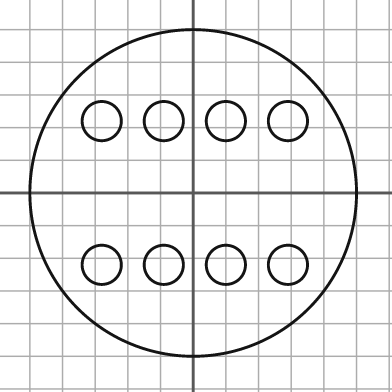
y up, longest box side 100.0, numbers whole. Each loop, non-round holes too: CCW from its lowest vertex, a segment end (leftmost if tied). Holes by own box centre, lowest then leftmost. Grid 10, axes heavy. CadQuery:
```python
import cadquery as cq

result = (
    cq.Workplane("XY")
    .moveTo(0.0, 0.0)
    .circle(50.0)
    .moveTo(-28.0, -22.0)
    .circle(6.0)
    .moveTo(-9.0, -22.0)
    .circle(6.0)
    .moveTo(10.0, -22.0)
    .circle(6.0)
    .moveTo(29.0, -22.0)
    .circle(6.0)
    .moveTo(-28.0, 22.0)
    .circle(6.0)
    .moveTo(-9.0, 22.0)
    .circle(6.0)
    .moveTo(10.0, 22.0)
    .circle(6.0)
    .moveTo(29.0, 22.0)
    .circle(6.0)
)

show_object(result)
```